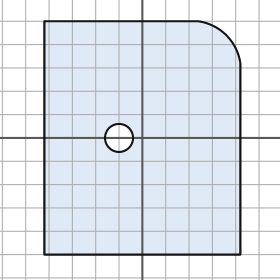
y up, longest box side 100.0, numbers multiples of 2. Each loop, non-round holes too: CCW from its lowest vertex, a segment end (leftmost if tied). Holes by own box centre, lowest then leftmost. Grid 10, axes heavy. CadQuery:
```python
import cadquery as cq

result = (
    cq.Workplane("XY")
    .moveTo(-42.0, -50.0)
    .lineTo(42.0, -50.0)
    .lineTo(42.0, 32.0)
    .threePointArc((36.0, 44.0), (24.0, 50.0))
    .lineTo(-42.0, 50.0)
    .close()
    .moveTo(-10.0, 0.0)
    .circle(6.0)
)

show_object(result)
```